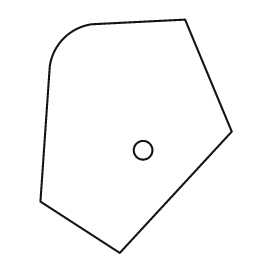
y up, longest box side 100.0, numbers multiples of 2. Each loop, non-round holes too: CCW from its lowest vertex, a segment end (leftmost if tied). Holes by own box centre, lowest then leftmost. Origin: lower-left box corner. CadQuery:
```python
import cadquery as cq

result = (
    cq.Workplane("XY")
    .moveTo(34.0, 0.0)
    .lineTo(82.0, 52.0)
    .lineTo(62.0, 100.0)
    .lineTo(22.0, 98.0)
    .threePointArc((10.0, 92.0), (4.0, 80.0))
    .lineTo(0.0, 22.0)
    .close()
    .moveTo(44.0, 44.0)
    .circle(4.0)
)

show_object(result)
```